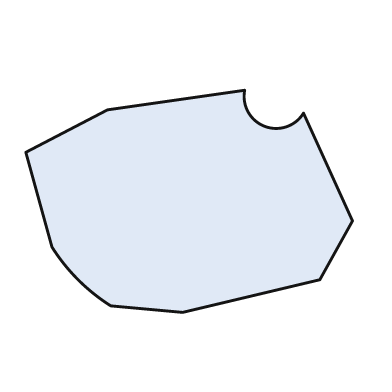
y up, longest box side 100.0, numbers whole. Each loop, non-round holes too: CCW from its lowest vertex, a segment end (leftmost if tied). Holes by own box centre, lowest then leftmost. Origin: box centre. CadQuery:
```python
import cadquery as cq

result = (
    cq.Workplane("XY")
    .moveTo(-2.0, -34.0)
    .lineTo(40.0, -24.0)
    .lineTo(50.0, -6.0)
    .lineTo(35.0, 27.0)
    .threePointArc((23.0, 23.0), (17.0, 34.0))
    .lineTo(-25.0, 28.0)
    .lineTo(-50.0, 15.0)
    .lineTo(-42.0, -14.0)
    .threePointArc((-34.0, -24.0), (-24.0, -32.0))
    .close()
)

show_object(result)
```